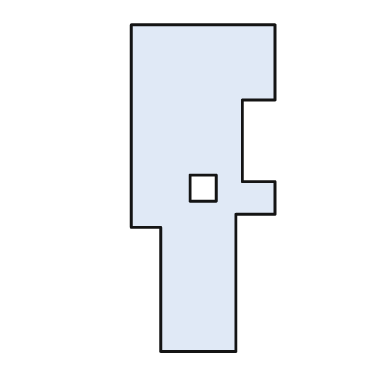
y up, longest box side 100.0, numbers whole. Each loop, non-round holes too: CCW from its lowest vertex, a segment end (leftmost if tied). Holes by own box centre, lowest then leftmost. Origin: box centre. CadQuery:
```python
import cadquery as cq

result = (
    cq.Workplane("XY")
    .moveTo(-13.0, -50.0)
    .lineTo(10.0, -50.0)
    .lineTo(10.0, -8.0)
    .lineTo(22.0, -8.0)
    .lineTo(22.0, 2.0)
    .lineTo(12.0, 2.0)
    .lineTo(12.0, 27.0)
    .lineTo(22.0, 27.0)
    .lineTo(22.0, 50.0)
    .lineTo(-22.0, 50.0)
    .lineTo(-22.0, -12.0)
    .lineTo(-13.0, -12.0)
    .close()
    .moveTo(-4.0, -4.0)
    .lineTo(4.0, -4.0)
    .lineTo(4.0, 4.0)
    .lineTo(-4.0, 4.0)
    .close()
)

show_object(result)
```